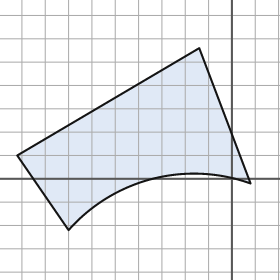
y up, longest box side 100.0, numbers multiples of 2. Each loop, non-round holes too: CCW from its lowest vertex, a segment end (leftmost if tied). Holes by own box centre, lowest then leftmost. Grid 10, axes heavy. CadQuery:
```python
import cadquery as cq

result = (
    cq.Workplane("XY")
    .moveTo(-70.0, -22.0)
    .threePointArc((-34.0, 0.0), (8.0, -2.0))
    .lineTo(-14.0, 56.0)
    .lineTo(-92.0, 10.0)
    .close()
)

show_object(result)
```